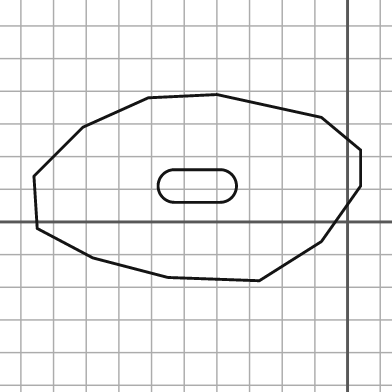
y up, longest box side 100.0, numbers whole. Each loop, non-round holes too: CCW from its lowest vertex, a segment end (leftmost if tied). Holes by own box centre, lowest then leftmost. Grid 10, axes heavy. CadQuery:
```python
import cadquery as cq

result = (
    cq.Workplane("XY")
    .moveTo(-27.0, -18.0)
    .lineTo(-8.0, -6.0)
    .lineTo(4.0, 11.0)
    .lineTo(4.0, 22.0)
    .lineTo(-8.0, 32.0)
    .lineTo(-40.0, 39.0)
    .lineTo(-61.0, 38.0)
    .lineTo(-81.0, 29.0)
    .lineTo(-96.0, 14.0)
    .lineTo(-95.0, -2.0)
    .lineTo(-78.0, -11.0)
    .lineTo(-55.0, -17.0)
    .close()
    .moveTo(-53.0, 6.0)
    .lineTo(-39.0, 6.0)
    .threePointArc((-34.0, 11.0), (-39.0, 16.0))
    .lineTo(-53.0, 16.0)
    .threePointArc((-58.0, 11.0), (-53.0, 6.0))
    .close()
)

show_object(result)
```